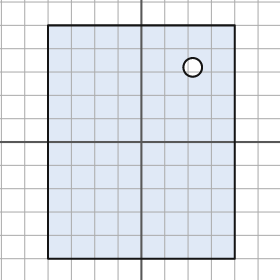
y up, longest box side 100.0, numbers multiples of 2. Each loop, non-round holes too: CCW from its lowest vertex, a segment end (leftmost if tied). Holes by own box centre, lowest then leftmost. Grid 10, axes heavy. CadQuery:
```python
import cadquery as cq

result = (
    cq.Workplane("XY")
    .moveTo(-40.0, -50.0)
    .lineTo(40.0, -50.0)
    .lineTo(40.0, 50.0)
    .lineTo(-40.0, 50.0)
    .close()
    .moveTo(22.0, 32.0)
    .circle(4.0)
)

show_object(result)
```